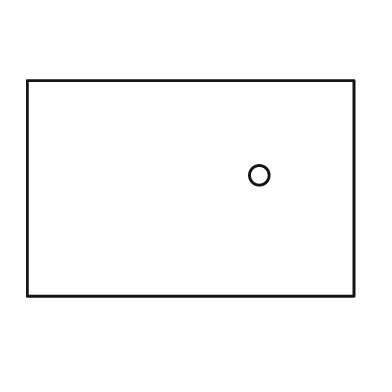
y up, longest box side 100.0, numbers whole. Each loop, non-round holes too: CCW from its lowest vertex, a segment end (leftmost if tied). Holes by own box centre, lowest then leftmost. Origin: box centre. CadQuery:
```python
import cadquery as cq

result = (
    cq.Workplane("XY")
    .moveTo(-50.0, -33.0)
    .lineTo(50.0, -33.0)
    .lineTo(50.0, 33.0)
    .lineTo(-50.0, 33.0)
    .close()
    .moveTo(21.0, 4.0)
    .circle(3.0)
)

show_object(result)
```